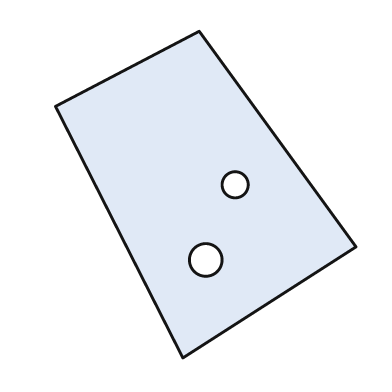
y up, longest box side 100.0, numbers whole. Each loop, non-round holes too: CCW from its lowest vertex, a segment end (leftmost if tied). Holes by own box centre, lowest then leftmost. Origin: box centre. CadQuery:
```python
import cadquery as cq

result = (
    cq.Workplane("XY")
    .moveTo(-7.0, -50.0)
    .lineTo(46.0, -16.0)
    .lineTo(-2.0, 50.0)
    .lineTo(-46.0, 27.0)
    .close()
    .moveTo(0.0, -20.0)
    .circle(5.0)
    .moveTo(9.0, 3.0)
    .circle(4.0)
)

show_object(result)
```